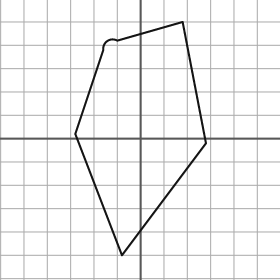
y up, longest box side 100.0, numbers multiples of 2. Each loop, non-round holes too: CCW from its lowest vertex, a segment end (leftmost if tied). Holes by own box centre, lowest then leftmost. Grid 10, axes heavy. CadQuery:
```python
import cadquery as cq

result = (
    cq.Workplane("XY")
    .moveTo(-8.0, -50.0)
    .lineTo(28.0, -2.0)
    .lineTo(18.0, 50.0)
    .lineTo(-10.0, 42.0)
    .threePointArc((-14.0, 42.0), (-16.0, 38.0))
    .lineTo(-28.0, 2.0)
    .close()
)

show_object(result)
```